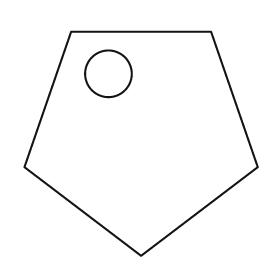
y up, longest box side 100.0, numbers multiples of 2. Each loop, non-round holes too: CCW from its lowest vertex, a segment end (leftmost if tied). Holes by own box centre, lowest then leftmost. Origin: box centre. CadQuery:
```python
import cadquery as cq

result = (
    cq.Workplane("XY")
    .moveTo(0.0, -48.0)
    .lineTo(50.0, -10.0)
    .lineTo(30.0, 48.0)
    .lineTo(-30.0, 48.0)
    .lineTo(-50.0, -10.0)
    .close()
    .moveTo(-14.0, 30.0)
    .circle(10.0)
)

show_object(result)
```